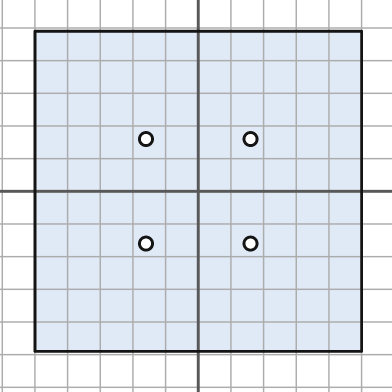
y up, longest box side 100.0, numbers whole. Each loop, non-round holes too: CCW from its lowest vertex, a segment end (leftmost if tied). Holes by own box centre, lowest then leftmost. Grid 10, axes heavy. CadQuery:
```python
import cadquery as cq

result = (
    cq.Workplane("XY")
    .moveTo(-50.0, -49.0)
    .lineTo(50.0, -49.0)
    .lineTo(50.0, 49.0)
    .lineTo(-50.0, 49.0)
    .close()
    .moveTo(-16.0, -16.0)
    .circle(2.0)
    .moveTo(16.0, -16.0)
    .circle(2.0)
    .moveTo(-16.0, 16.0)
    .circle(2.0)
    .moveTo(16.0, 16.0)
    .circle(2.0)
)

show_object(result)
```